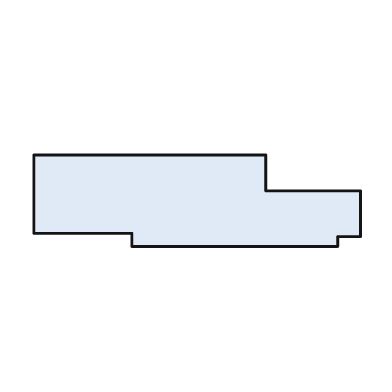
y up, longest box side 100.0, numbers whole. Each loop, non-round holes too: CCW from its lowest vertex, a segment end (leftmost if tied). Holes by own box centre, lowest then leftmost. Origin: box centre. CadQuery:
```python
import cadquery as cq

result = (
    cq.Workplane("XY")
    .moveTo(-20.0, -14.0)
    .lineTo(43.0, -14.0)
    .lineTo(43.0, -11.0)
    .lineTo(50.0, -11.0)
    .lineTo(50.0, 3.0)
    .lineTo(21.0, 3.0)
    .lineTo(21.0, 14.0)
    .lineTo(-50.0, 14.0)
    .lineTo(-50.0, -10.0)
    .lineTo(-20.0, -10.0)
    .close()
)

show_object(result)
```